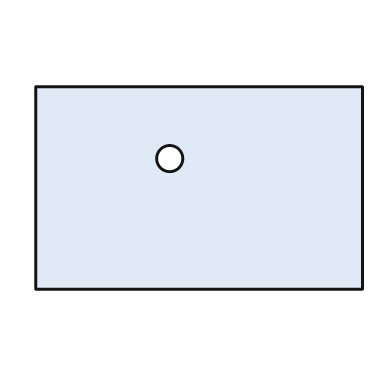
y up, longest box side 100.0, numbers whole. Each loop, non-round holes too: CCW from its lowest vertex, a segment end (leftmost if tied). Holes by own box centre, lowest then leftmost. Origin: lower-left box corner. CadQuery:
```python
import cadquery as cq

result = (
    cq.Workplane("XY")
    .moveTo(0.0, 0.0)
    .lineTo(100.0, 0.0)
    .lineTo(100.0, 62.0)
    .lineTo(0.0, 62.0)
    .close()
    .moveTo(41.0, 40.0)
    .circle(4.0)
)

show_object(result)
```